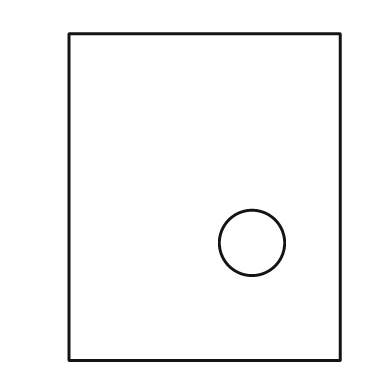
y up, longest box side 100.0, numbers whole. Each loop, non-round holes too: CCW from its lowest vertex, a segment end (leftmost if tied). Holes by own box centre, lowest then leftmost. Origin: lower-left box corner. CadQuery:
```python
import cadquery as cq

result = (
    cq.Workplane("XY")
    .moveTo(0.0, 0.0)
    .lineTo(83.0, 0.0)
    .lineTo(83.0, 100.0)
    .lineTo(0.0, 100.0)
    .close()
    .moveTo(56.0, 36.0)
    .circle(10.0)
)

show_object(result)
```